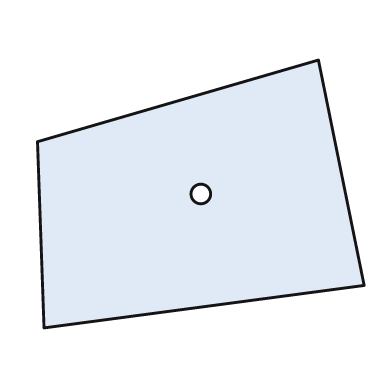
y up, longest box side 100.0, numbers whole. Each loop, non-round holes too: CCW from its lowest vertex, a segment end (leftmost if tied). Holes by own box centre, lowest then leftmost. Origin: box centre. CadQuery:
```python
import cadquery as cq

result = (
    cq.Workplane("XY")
    .moveTo(-48.0, -41.0)
    .lineTo(50.0, -28.0)
    .lineTo(36.0, 41.0)
    .lineTo(-50.0, 16.0)
    .close()
    .moveTo(0.0, 0.0)
    .circle(3.0)
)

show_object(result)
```